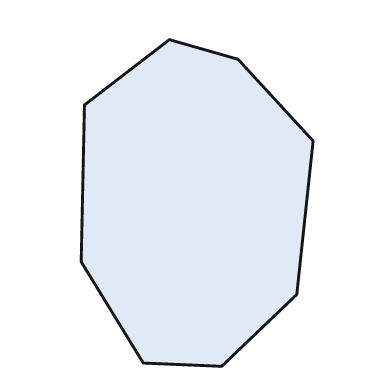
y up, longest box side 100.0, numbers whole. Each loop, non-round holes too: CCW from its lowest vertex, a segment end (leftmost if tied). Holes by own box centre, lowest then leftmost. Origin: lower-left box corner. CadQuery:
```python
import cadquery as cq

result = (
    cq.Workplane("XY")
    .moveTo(43.0, 0.0)
    .lineTo(66.0, 22.0)
    .lineTo(71.0, 69.0)
    .lineTo(48.0, 94.0)
    .lineTo(27.0, 100.0)
    .lineTo(1.0, 80.0)
    .lineTo(0.0, 32.0)
    .lineTo(19.0, 1.0)
    .close()
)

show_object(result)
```